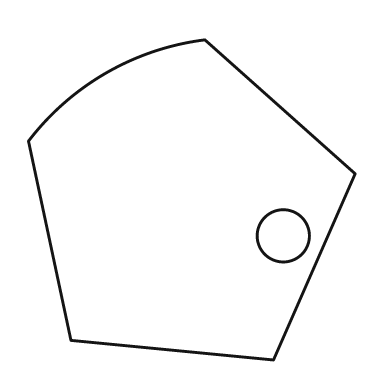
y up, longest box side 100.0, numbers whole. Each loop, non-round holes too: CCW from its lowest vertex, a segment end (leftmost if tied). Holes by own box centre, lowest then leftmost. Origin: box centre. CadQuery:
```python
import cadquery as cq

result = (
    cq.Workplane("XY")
    .moveTo(25.0, -49.0)
    .lineTo(50.0, 8.0)
    .lineTo(4.0, 49.0)
    .threePointArc((-26.0, 39.0), (-50.0, 18.0))
    .lineTo(-37.0, -43.0)
    .close()
    .moveTo(28.0, -11.0)
    .circle(8.0)
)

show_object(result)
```